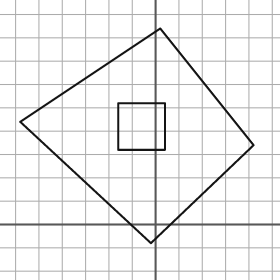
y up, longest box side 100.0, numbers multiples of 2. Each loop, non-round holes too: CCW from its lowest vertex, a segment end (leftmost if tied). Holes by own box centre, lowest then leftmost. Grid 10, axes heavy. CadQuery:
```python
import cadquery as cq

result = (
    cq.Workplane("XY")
    .moveTo(-2.0, -8.0)
    .lineTo(42.0, 34.0)
    .lineTo(2.0, 84.0)
    .lineTo(-58.0, 44.0)
    .close()
    .moveTo(-16.0, 32.0)
    .lineTo(4.0, 32.0)
    .lineTo(4.0, 52.0)
    .lineTo(-16.0, 52.0)
    .close()
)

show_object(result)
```